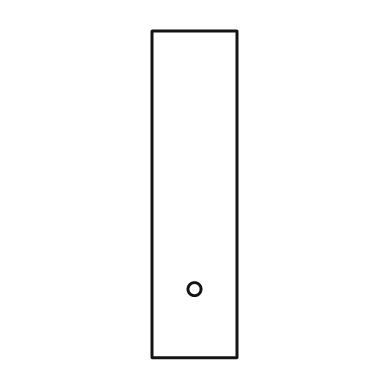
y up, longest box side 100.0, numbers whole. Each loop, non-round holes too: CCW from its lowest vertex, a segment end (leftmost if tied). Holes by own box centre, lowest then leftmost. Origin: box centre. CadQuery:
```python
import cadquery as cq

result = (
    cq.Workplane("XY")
    .moveTo(-13.0, -50.0)
    .lineTo(13.0, -50.0)
    .lineTo(13.0, 50.0)
    .lineTo(-13.0, 50.0)
    .close()
    .moveTo(0.0, -29.0)
    .circle(2.0)
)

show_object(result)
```